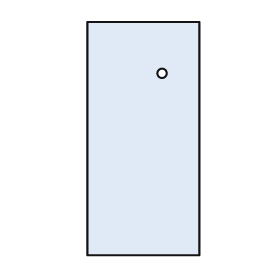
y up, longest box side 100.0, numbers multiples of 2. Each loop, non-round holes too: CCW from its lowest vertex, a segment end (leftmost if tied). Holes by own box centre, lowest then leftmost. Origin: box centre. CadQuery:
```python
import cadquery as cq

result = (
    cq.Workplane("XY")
    .moveTo(-24.0, -50.0)
    .lineTo(24.0, -50.0)
    .lineTo(24.0, 50.0)
    .lineTo(-24.0, 50.0)
    .close()
    .moveTo(8.0, 28.0)
    .circle(2.0)
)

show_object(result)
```